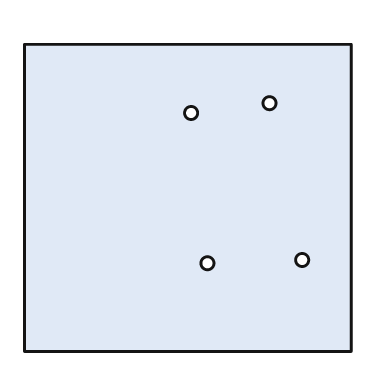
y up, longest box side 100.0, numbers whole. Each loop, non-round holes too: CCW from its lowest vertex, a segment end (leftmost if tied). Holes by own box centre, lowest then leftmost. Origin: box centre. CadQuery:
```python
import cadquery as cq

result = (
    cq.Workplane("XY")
    .moveTo(-50.0, -47.0)
    .lineTo(50.0, -47.0)
    .lineTo(50.0, 47.0)
    .lineTo(-50.0, 47.0)
    .close()
    .moveTo(6.0, -20.0)
    .circle(2.0)
    .moveTo(35.0, -19.0)
    .circle(2.0)
    .moveTo(1.0, 26.0)
    .circle(2.0)
    .moveTo(25.0, 29.0)
    .circle(2.0)
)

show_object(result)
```